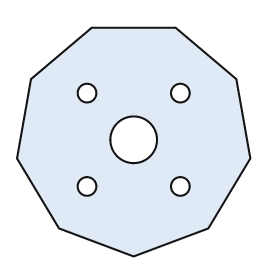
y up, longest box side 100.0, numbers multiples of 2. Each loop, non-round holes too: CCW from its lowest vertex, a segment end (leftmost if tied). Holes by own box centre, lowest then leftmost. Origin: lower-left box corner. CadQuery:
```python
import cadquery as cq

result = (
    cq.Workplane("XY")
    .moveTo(50.0, 0.0)
    .lineTo(82.0, 12.0)
    .lineTo(100.0, 42.0)
    .lineTo(94.0, 76.0)
    .lineTo(68.0, 98.0)
    .lineTo(32.0, 98.0)
    .lineTo(6.0, 76.0)
    .lineTo(0.0, 42.0)
    .lineTo(18.0, 12.0)
    .close()
    .moveTo(30.0, 30.0)
    .circle(4.0)
    .moveTo(70.0, 30.0)
    .circle(4.0)
    .moveTo(50.0, 50.0)
    .circle(10.0)
    .moveTo(30.0, 70.0)
    .circle(4.0)
    .moveTo(70.0, 70.0)
    .circle(4.0)
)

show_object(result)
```